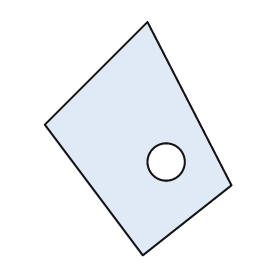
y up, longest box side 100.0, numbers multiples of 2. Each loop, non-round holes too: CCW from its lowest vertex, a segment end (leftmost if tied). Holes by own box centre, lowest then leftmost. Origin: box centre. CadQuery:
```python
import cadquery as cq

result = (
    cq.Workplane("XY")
    .moveTo(2.0, -50.0)
    .lineTo(40.0, -20.0)
    .lineTo(4.0, 50.0)
    .lineTo(-40.0, 6.0)
    .close()
    .moveTo(12.0, -10.0)
    .circle(8.0)
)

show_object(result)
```